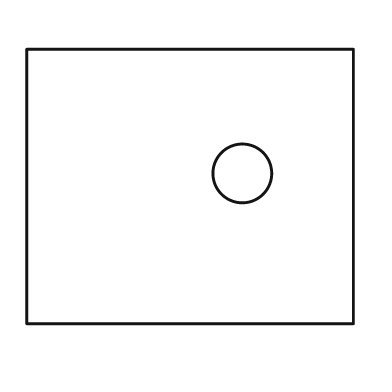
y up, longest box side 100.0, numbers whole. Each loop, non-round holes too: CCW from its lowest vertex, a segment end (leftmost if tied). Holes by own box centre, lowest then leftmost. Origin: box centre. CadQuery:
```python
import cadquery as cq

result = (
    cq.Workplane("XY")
    .moveTo(-50.0, -42.0)
    .lineTo(50.0, -42.0)
    .lineTo(50.0, 42.0)
    .lineTo(-50.0, 42.0)
    .close()
    .moveTo(16.0, 4.0)
    .circle(9.0)
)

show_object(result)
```